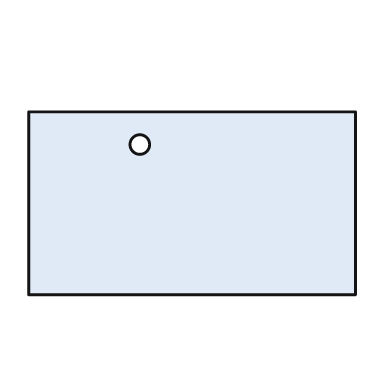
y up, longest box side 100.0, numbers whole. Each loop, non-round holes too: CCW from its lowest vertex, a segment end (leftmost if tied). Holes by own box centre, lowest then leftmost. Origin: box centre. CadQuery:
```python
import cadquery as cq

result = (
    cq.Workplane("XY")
    .moveTo(-50.0, -28.0)
    .lineTo(50.0, -28.0)
    .lineTo(50.0, 28.0)
    .lineTo(-50.0, 28.0)
    .close()
    .moveTo(-16.0, 18.0)
    .circle(3.0)
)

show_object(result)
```